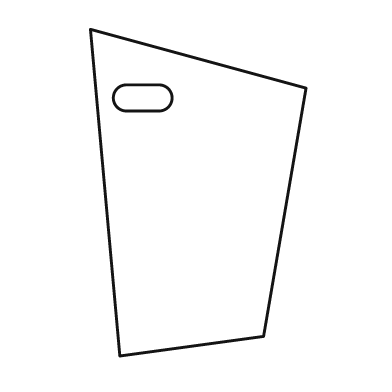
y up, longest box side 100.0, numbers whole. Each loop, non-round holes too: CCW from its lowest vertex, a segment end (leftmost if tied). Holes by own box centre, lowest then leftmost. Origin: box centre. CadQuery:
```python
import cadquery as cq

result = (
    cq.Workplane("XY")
    .moveTo(-24.0, -50.0)
    .lineTo(20.0, -44.0)
    .lineTo(33.0, 32.0)
    .lineTo(-33.0, 50.0)
    .close()
    .moveTo(-22.0, 25.0)
    .lineTo(-12.0, 25.0)
    .threePointArc((-8.0, 29.0), (-12.0, 33.0))
    .lineTo(-22.0, 33.0)
    .threePointArc((-26.0, 29.0), (-22.0, 25.0))
    .close()
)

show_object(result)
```